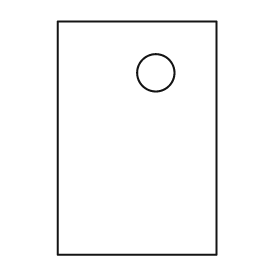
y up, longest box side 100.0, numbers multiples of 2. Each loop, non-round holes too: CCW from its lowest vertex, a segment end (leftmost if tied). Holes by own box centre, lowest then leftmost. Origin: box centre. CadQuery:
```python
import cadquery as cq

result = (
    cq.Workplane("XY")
    .moveTo(-34.0, -50.0)
    .lineTo(34.0, -50.0)
    .lineTo(34.0, 50.0)
    .lineTo(-34.0, 50.0)
    .close()
    .moveTo(8.0, 28.0)
    .circle(8.0)
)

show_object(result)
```